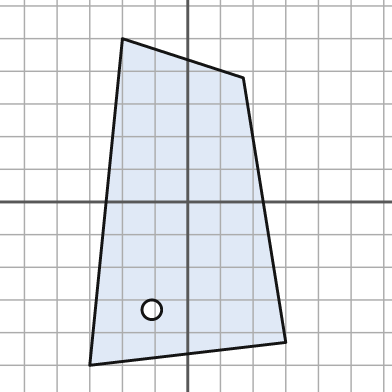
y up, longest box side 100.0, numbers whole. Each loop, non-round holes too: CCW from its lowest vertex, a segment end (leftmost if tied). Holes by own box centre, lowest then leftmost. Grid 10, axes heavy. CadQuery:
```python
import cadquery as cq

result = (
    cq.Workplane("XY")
    .moveTo(-30.0, -50.0)
    .lineTo(30.0, -43.0)
    .lineTo(17.0, 38.0)
    .lineTo(-20.0, 50.0)
    .close()
    .moveTo(-11.0, -33.0)
    .circle(3.0)
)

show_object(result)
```